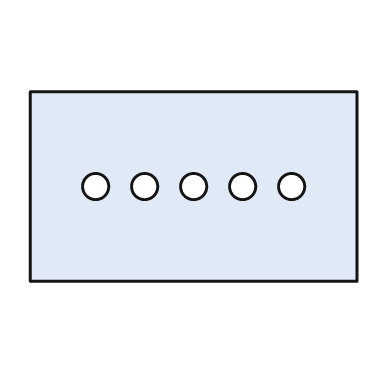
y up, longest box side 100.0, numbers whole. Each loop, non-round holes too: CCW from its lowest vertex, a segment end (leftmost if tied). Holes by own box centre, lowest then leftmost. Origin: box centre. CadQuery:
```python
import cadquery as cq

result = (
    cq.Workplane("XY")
    .moveTo(-50.0, -29.0)
    .lineTo(50.0, -29.0)
    .lineTo(50.0, 29.0)
    .lineTo(-50.0, 29.0)
    .close()
    .moveTo(-30.0, 0.0)
    .circle(4.0)
    .moveTo(-15.0, 0.0)
    .circle(4.0)
    .moveTo(0.0, 0.0)
    .circle(4.0)
    .moveTo(15.0, 0.0)
    .circle(4.0)
    .moveTo(30.0, 0.0)
    .circle(4.0)
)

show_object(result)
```